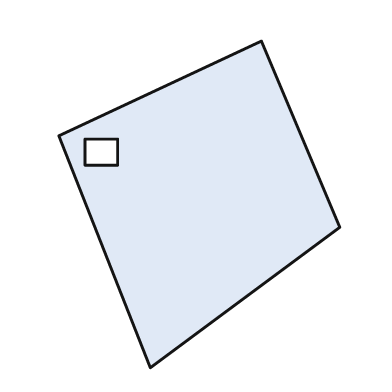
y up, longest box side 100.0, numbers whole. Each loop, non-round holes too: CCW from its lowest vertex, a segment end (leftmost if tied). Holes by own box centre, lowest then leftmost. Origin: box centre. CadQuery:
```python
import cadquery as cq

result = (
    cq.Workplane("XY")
    .moveTo(-15.0, -50.0)
    .lineTo(43.0, -7.0)
    .lineTo(19.0, 50.0)
    .lineTo(-43.0, 21.0)
    .close()
    .moveTo(-35.0, 12.0)
    .lineTo(-25.0, 12.0)
    .lineTo(-25.0, 20.0)
    .lineTo(-35.0, 20.0)
    .close()
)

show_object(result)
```